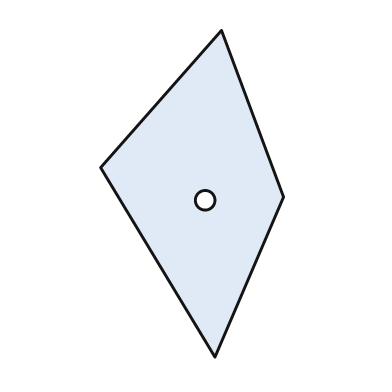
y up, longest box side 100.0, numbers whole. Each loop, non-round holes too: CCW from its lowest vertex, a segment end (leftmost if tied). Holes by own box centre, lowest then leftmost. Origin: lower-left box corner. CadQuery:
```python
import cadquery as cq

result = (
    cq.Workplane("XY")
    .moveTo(35.0, 0.0)
    .lineTo(56.0, 49.0)
    .lineTo(37.0, 100.0)
    .lineTo(0.0, 58.0)
    .close()
    .moveTo(32.0, 48.0)
    .circle(3.0)
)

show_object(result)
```